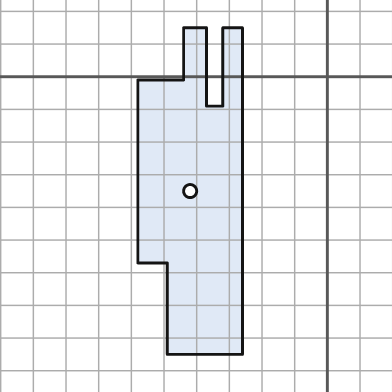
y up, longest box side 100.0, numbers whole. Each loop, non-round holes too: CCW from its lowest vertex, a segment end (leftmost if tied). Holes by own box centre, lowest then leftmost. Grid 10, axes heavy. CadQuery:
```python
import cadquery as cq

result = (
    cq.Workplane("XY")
    .moveTo(-49.0, -85.0)
    .lineTo(-26.0, -85.0)
    .lineTo(-26.0, 15.0)
    .lineTo(-32.0, 15.0)
    .lineTo(-32.0, -9.0)
    .lineTo(-37.0, -9.0)
    .lineTo(-37.0, 15.0)
    .lineTo(-44.0, 15.0)
    .lineTo(-44.0, -1.0)
    .lineTo(-58.0, -1.0)
    .lineTo(-58.0, -57.0)
    .lineTo(-49.0, -57.0)
    .close()
    .moveTo(-42.0, -35.0)
    .circle(2.0)
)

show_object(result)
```